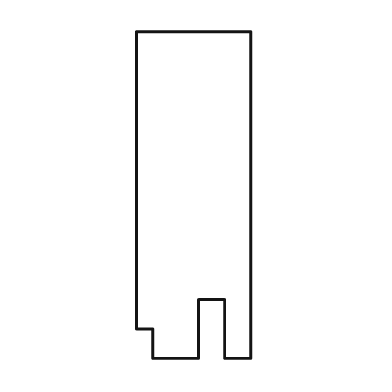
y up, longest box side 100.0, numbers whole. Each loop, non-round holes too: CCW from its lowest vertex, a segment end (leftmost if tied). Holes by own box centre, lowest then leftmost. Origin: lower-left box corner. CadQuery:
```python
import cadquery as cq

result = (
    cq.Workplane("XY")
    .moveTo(5.0, 0.0)
    .lineTo(19.0, 0.0)
    .lineTo(19.0, 18.0)
    .lineTo(27.0, 18.0)
    .lineTo(27.0, 0.0)
    .lineTo(35.0, 0.0)
    .lineTo(35.0, 100.0)
    .lineTo(0.0, 100.0)
    .lineTo(0.0, 9.0)
    .lineTo(5.0, 9.0)
    .close()
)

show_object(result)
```